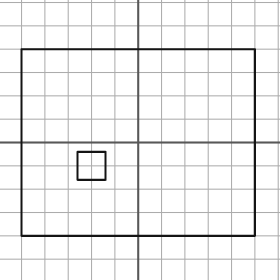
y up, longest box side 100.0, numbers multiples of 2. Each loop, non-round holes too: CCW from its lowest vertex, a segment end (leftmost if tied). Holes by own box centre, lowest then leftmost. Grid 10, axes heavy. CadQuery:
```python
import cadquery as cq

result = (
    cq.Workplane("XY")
    .moveTo(-50.0, -40.0)
    .lineTo(50.0, -40.0)
    .lineTo(50.0, 40.0)
    .lineTo(-50.0, 40.0)
    .close()
    .moveTo(-26.0, -16.0)
    .lineTo(-14.0, -16.0)
    .lineTo(-14.0, -4.0)
    .lineTo(-26.0, -4.0)
    .close()
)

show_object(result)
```